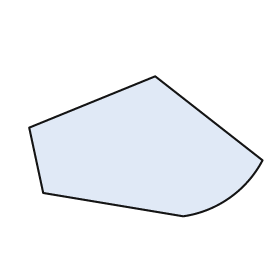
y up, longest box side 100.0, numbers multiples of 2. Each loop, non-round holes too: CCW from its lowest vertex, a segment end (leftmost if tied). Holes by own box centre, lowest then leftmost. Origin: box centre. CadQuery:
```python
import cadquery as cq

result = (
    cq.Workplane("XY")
    .moveTo(16.0, -30.0)
    .threePointArc((36.0, -22.0), (50.0, -6.0))
    .lineTo(4.0, 30.0)
    .lineTo(-50.0, 8.0)
    .lineTo(-44.0, -20.0)
    .close()
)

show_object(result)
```